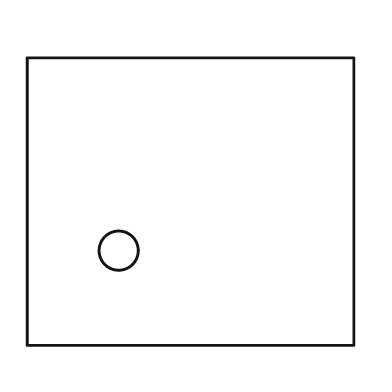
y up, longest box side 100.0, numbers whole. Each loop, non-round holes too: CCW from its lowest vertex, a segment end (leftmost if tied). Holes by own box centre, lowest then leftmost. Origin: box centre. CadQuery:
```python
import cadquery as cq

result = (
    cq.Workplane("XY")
    .moveTo(-50.0, -44.0)
    .lineTo(50.0, -44.0)
    .lineTo(50.0, 44.0)
    .lineTo(-50.0, 44.0)
    .close()
    .moveTo(-22.0, -15.0)
    .circle(6.0)
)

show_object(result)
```